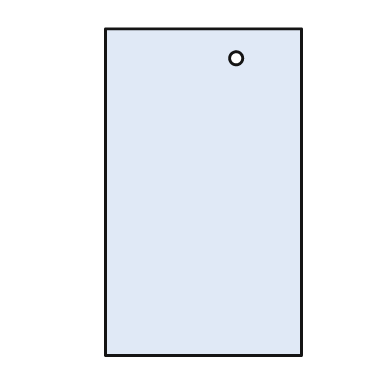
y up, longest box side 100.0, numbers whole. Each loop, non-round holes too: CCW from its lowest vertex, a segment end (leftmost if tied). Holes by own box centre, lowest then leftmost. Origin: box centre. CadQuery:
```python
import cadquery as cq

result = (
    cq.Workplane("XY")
    .moveTo(-30.0, -50.0)
    .lineTo(30.0, -50.0)
    .lineTo(30.0, 50.0)
    .lineTo(-30.0, 50.0)
    .close()
    .moveTo(10.0, 41.0)
    .circle(2.0)
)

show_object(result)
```